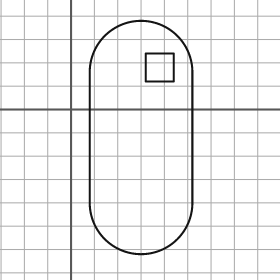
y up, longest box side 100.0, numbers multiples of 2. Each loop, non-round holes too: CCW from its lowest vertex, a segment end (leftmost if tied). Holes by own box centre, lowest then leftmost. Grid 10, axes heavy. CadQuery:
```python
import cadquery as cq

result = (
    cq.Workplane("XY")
    .moveTo(8.0, -40.0)
    .threePointArc((30.0, -62.0), (52.0, -40.0))
    .lineTo(52.0, 16.0)
    .threePointArc((30.0, 38.0), (8.0, 16.0))
    .close()
    .moveTo(32.0, 12.0)
    .lineTo(44.0, 12.0)
    .lineTo(44.0, 24.0)
    .lineTo(32.0, 24.0)
    .close()
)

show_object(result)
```